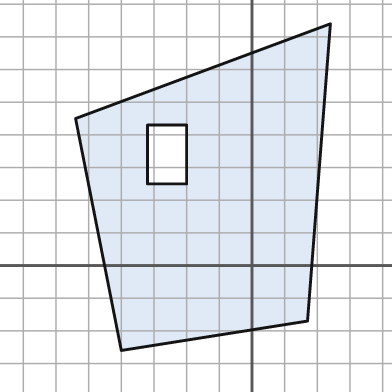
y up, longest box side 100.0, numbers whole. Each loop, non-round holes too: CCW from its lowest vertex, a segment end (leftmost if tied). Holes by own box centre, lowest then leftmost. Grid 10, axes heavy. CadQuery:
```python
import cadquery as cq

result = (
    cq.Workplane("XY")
    .moveTo(-40.0, -26.0)
    .lineTo(17.0, -17.0)
    .lineTo(24.0, 74.0)
    .lineTo(-54.0, 45.0)
    .close()
    .moveTo(-32.0, 25.0)
    .lineTo(-20.0, 25.0)
    .lineTo(-20.0, 43.0)
    .lineTo(-32.0, 43.0)
    .close()
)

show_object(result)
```